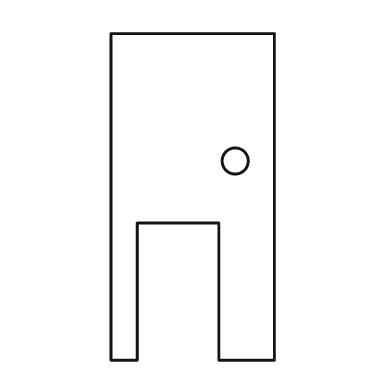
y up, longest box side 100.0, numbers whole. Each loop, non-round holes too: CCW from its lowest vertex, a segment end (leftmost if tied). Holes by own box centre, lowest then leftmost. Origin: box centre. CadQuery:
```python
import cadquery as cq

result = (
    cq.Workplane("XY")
    .moveTo(-25.0, -50.0)
    .lineTo(-17.0, -50.0)
    .lineTo(-17.0, -8.0)
    .lineTo(8.0, -8.0)
    .lineTo(8.0, -50.0)
    .lineTo(25.0, -50.0)
    .lineTo(25.0, 50.0)
    .lineTo(-25.0, 50.0)
    .close()
    .moveTo(13.0, 11.0)
    .circle(4.0)
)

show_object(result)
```